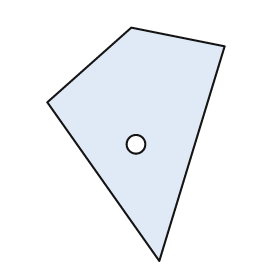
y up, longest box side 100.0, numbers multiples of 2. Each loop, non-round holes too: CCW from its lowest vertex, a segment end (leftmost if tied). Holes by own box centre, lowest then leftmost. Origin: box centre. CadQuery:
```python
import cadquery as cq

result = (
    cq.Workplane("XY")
    .moveTo(10.0, -50.0)
    .lineTo(38.0, 42.0)
    .lineTo(-2.0, 50.0)
    .lineTo(-38.0, 18.0)
    .close()
    .moveTo(0.0, 0.0)
    .circle(4.0)
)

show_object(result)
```